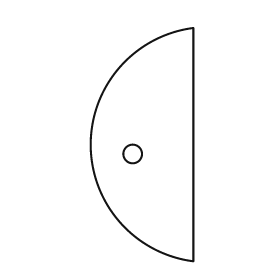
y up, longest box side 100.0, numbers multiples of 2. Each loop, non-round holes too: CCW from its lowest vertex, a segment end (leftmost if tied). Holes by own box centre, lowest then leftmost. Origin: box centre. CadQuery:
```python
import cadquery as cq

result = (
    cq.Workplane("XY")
    .moveTo(22.0, -50.0)
    .lineTo(22.0, 50.0)
    .threePointArc((-22.0, 0.0), (22.0, -50.0))
    .close()
    .moveTo(-4.0, -4.0)
    .circle(4.0)
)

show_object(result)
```